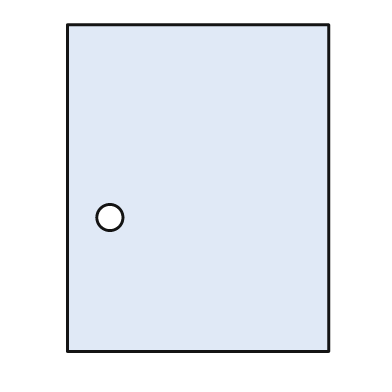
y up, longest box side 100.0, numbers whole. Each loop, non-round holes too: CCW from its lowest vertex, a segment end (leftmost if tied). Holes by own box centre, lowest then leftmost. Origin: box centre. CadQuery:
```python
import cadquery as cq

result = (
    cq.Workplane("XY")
    .moveTo(-40.0, -50.0)
    .lineTo(40.0, -50.0)
    .lineTo(40.0, 50.0)
    .lineTo(-40.0, 50.0)
    .close()
    .moveTo(-27.0, -9.0)
    .circle(4.0)
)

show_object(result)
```